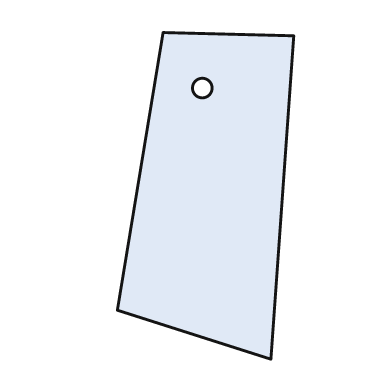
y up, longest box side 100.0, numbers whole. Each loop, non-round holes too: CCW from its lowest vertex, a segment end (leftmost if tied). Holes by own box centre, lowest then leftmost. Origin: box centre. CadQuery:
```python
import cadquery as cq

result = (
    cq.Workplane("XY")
    .moveTo(20.0, -50.0)
    .lineTo(27.0, 49.0)
    .lineTo(-13.0, 50.0)
    .lineTo(-27.0, -35.0)
    .close()
    .moveTo(-1.0, 33.0)
    .circle(3.0)
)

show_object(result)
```